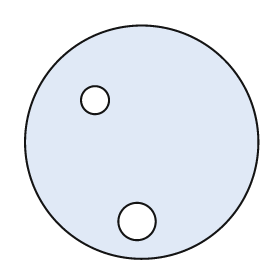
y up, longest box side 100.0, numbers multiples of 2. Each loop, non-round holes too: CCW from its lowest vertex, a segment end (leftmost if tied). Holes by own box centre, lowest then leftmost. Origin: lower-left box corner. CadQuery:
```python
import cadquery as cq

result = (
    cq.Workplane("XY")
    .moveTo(50.0, 50.0)
    .circle(50.0)
    .moveTo(48.0, 16.0)
    .circle(8.0)
    .moveTo(30.0, 68.0)
    .circle(6.0)
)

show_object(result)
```